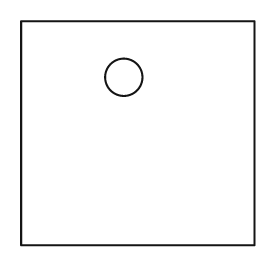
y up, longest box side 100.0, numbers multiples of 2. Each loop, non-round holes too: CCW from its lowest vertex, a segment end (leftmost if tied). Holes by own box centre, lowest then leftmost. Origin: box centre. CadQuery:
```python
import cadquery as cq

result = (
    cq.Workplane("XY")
    .moveTo(-50.0, -48.0)
    .lineTo(50.0, -48.0)
    .lineTo(50.0, 48.0)
    .lineTo(-50.0, 48.0)
    .close()
    .moveTo(-6.0, 24.0)
    .circle(8.0)
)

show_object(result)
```